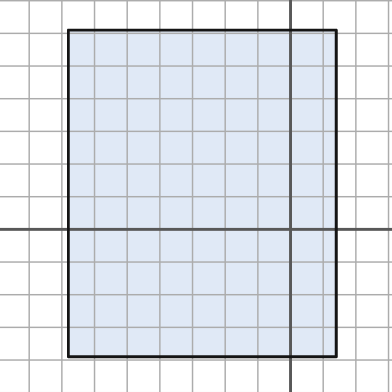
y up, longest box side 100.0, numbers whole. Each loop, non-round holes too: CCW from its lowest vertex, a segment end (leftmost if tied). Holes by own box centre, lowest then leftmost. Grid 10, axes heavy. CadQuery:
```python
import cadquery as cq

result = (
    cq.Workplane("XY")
    .moveTo(-68.0, -39.0)
    .lineTo(14.0, -39.0)
    .lineTo(14.0, 61.0)
    .lineTo(-68.0, 61.0)
    .close()
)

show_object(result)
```